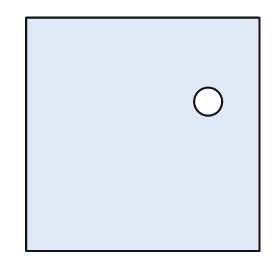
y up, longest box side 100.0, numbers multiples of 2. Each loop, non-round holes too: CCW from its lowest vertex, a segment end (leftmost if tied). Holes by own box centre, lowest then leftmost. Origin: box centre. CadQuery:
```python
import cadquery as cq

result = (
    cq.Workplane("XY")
    .moveTo(-50.0, -50.0)
    .lineTo(50.0, -50.0)
    .lineTo(50.0, 50.0)
    .lineTo(-50.0, 50.0)
    .close()
    .moveTo(28.0, 14.0)
    .circle(6.0)
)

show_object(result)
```